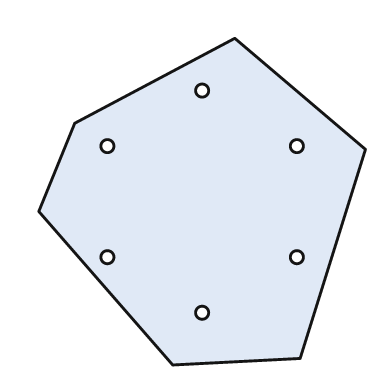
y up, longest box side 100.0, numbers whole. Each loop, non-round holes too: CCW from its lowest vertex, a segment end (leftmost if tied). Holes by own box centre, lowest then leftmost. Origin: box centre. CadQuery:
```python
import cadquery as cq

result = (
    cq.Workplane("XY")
    .moveTo(-9.0, -50.0)
    .lineTo(30.0, -48.0)
    .lineTo(50.0, 16.0)
    .lineTo(10.0, 50.0)
    .lineTo(-39.0, 24.0)
    .lineTo(-50.0, -3.0)
    .close()
    .moveTo(0.0, -34.0)
    .circle(2.0)
    .moveTo(-29.0, -17.0)
    .circle(2.0)
    .moveTo(29.0, -17.0)
    .circle(2.0)
    .moveTo(-29.0, 17.0)
    .circle(2.0)
    .moveTo(29.0, 17.0)
    .circle(2.0)
    .moveTo(0.0, 34.0)
    .circle(2.0)
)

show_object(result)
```